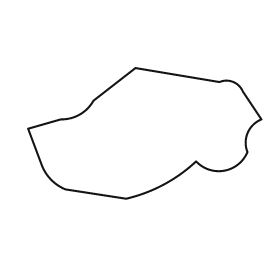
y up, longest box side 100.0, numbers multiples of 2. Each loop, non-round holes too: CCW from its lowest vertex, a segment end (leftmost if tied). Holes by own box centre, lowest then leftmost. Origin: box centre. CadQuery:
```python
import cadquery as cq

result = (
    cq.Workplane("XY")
    .moveTo(-8.0, -28.0)
    .threePointArc((8.0, -22.0), (22.0, -12.0))
    .threePointArc((34.0, -16.0), (44.0, -8.0))
    .threePointArc((44.0, 0.0), (50.0, 6.0))
    .lineTo(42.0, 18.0)
    .threePointArc((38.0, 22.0), (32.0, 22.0))
    .lineTo(-4.0, 28.0)
    .lineTo(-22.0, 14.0)
    .threePointArc((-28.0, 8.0), (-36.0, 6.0))
    .lineTo(-50.0, 2.0)
    .lineTo(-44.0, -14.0)
    .threePointArc((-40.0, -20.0), (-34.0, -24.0))
    .close()
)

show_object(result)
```